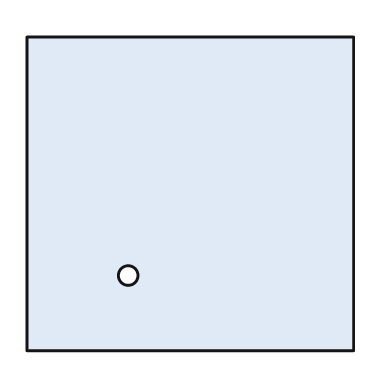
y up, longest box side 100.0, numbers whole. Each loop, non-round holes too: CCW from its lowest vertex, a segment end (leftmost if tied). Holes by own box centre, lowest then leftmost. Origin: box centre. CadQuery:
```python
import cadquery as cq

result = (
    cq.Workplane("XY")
    .moveTo(-50.0, -48.0)
    .lineTo(50.0, -48.0)
    .lineTo(50.0, 48.0)
    .lineTo(-50.0, 48.0)
    .close()
    .moveTo(-19.0, -25.0)
    .circle(3.0)
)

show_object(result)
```